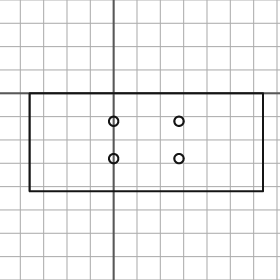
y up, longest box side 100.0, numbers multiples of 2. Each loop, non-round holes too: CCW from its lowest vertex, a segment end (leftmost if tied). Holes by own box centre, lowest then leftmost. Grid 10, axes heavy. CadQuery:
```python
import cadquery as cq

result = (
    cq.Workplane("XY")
    .moveTo(-36.0, -42.0)
    .lineTo(64.0, -42.0)
    .lineTo(64.0, 0.0)
    .lineTo(-36.0, 0.0)
    .close()
    .moveTo(0.0, -28.0)
    .circle(2.0)
    .moveTo(28.0, -28.0)
    .circle(2.0)
    .moveTo(0.0, -12.0)
    .circle(2.0)
    .moveTo(28.0, -12.0)
    .circle(2.0)
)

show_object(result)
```